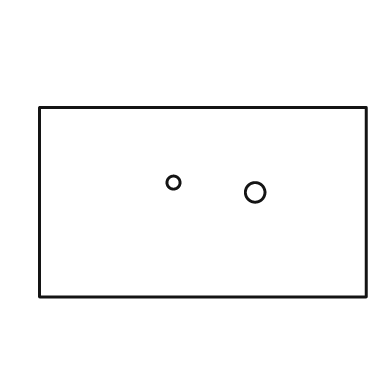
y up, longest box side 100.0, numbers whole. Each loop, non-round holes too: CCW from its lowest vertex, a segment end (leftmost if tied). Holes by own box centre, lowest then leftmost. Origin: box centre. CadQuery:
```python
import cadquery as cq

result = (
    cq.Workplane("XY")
    .moveTo(-50.0, -29.0)
    .lineTo(50.0, -29.0)
    .lineTo(50.0, 29.0)
    .lineTo(-50.0, 29.0)
    .close()
    .moveTo(16.0, 3.0)
    .circle(3.0)
    .moveTo(-9.0, 6.0)
    .circle(2.0)
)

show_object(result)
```